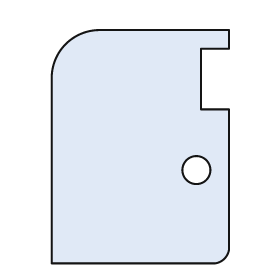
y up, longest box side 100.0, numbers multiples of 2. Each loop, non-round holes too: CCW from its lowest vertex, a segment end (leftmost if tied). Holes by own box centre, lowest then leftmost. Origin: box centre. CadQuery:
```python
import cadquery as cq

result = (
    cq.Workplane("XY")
    .moveTo(-38.0, -50.0)
    .lineTo(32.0, -50.0)
    .threePointArc((36.0, -48.0), (38.0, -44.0))
    .lineTo(38.0, 16.0)
    .lineTo(26.0, 16.0)
    .lineTo(26.0, 42.0)
    .lineTo(38.0, 42.0)
    .lineTo(38.0, 50.0)
    .lineTo(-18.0, 50.0)
    .threePointArc((-32.0, 44.0), (-38.0, 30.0))
    .close()
    .moveTo(24.0, -10.0)
    .circle(6.0)
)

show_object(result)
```